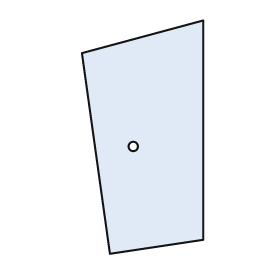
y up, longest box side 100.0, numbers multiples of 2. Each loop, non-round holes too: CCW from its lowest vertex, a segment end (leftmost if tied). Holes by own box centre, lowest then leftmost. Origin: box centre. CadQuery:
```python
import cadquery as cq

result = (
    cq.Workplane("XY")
    .moveTo(-14.0, -50.0)
    .lineTo(26.0, -44.0)
    .lineTo(26.0, 50.0)
    .lineTo(-26.0, 36.0)
    .close()
    .moveTo(-4.0, -4.0)
    .circle(2.0)
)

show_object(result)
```